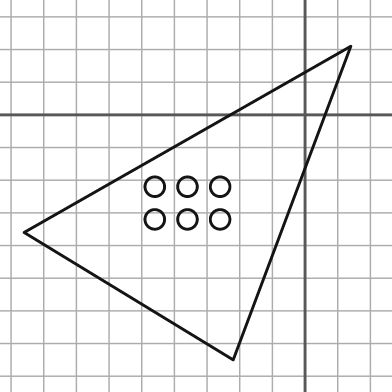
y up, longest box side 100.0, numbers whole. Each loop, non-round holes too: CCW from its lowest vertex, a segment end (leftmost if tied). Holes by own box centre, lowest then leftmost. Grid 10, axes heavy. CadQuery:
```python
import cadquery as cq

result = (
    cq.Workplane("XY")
    .moveTo(-22.0, -75.0)
    .lineTo(14.0, 21.0)
    .lineTo(-86.0, -36.0)
    .close()
    .moveTo(-46.0, -32.0)
    .circle(3.0)
    .moveTo(-36.0, -32.0)
    .circle(3.0)
    .moveTo(-26.0, -32.0)
    .circle(3.0)
    .moveTo(-46.0, -22.0)
    .circle(3.0)
    .moveTo(-36.0, -22.0)
    .circle(3.0)
    .moveTo(-26.0, -22.0)
    .circle(3.0)
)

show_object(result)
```